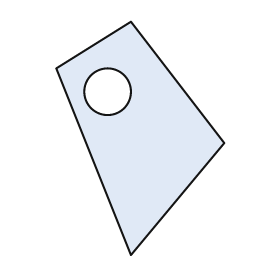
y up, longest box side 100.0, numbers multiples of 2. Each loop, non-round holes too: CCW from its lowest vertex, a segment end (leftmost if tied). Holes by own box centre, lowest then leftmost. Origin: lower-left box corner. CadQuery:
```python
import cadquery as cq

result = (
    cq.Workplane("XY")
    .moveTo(32.0, 0.0)
    .lineTo(72.0, 48.0)
    .lineTo(32.0, 100.0)
    .lineTo(0.0, 80.0)
    .close()
    .moveTo(22.0, 70.0)
    .circle(10.0)
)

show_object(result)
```